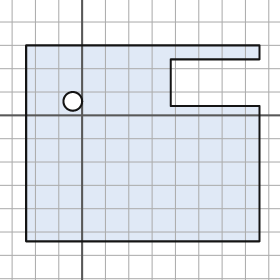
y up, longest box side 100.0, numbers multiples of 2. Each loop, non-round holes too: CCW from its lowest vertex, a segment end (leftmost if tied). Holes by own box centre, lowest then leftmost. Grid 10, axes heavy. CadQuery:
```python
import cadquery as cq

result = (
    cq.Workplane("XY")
    .moveTo(-24.0, -54.0)
    .lineTo(76.0, -54.0)
    .lineTo(76.0, 4.0)
    .lineTo(38.0, 4.0)
    .lineTo(38.0, 24.0)
    .lineTo(76.0, 24.0)
    .lineTo(76.0, 30.0)
    .lineTo(-24.0, 30.0)
    .close()
    .moveTo(-4.0, 6.0)
    .circle(4.0)
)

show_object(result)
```